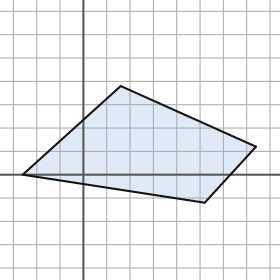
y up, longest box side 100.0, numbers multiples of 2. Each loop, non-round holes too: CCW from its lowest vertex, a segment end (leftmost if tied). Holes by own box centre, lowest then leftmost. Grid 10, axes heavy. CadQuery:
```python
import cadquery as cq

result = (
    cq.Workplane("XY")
    .moveTo(52.0, -12.0)
    .lineTo(74.0, 12.0)
    .lineTo(16.0, 38.0)
    .lineTo(-26.0, 0.0)
    .close()
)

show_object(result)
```